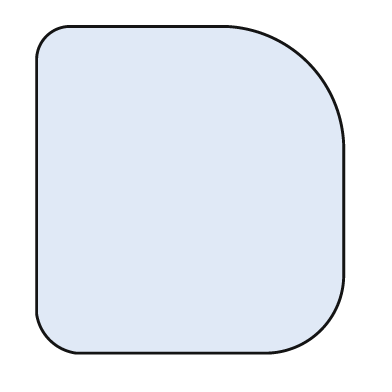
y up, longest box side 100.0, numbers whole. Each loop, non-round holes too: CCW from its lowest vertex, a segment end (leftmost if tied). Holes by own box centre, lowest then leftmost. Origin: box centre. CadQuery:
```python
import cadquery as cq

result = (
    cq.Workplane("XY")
    .moveTo(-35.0, -50.0)
    .lineTo(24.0, -50.0)
    .threePointArc((40.0, -43.0), (47.0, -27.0))
    .lineTo(47.0, 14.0)
    .threePointArc((36.0, 39.0), (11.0, 50.0))
    .lineTo(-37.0, 50.0)
    .threePointArc((-44.0, 47.0), (-47.0, 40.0))
    .lineTo(-47.0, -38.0)
    .threePointArc((-43.0, -46.0), (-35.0, -50.0))
    .close()
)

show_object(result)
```